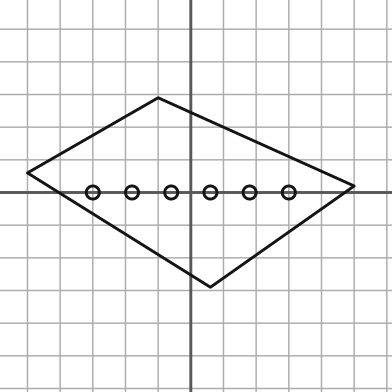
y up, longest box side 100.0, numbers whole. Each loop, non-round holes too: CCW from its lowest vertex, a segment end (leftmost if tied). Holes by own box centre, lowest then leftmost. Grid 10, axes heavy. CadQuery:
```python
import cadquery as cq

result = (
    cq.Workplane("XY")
    .moveTo(6.0, -29.0)
    .lineTo(50.0, 2.0)
    .lineTo(-10.0, 29.0)
    .lineTo(-50.0, 6.0)
    .close()
    .moveTo(-30.0, 0.0)
    .circle(2.0)
    .moveTo(-18.0, 0.0)
    .circle(2.0)
    .moveTo(-6.0, 0.0)
    .circle(2.0)
    .moveTo(6.0, 0.0)
    .circle(2.0)
    .moveTo(18.0, 0.0)
    .circle(2.0)
    .moveTo(30.0, 0.0)
    .circle(2.0)
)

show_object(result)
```